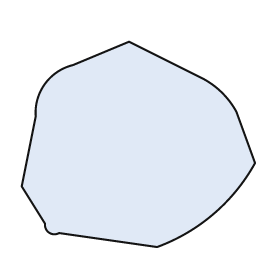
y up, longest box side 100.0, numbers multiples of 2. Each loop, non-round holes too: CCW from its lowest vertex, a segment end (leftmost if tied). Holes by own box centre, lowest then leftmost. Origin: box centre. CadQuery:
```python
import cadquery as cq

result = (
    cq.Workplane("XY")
    .moveTo(8.0, -44.0)
    .threePointArc((32.0, -30.0), (50.0, -8.0))
    .lineTo(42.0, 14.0)
    .threePointArc((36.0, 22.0), (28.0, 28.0))
    .lineTo(-4.0, 44.0)
    .lineTo(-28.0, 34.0)
    .threePointArc((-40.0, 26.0), (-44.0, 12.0))
    .lineTo(-50.0, -18.0)
    .lineTo(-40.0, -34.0)
    .threePointArc((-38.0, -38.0), (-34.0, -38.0))
    .close()
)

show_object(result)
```